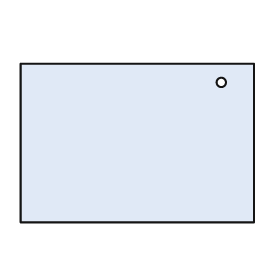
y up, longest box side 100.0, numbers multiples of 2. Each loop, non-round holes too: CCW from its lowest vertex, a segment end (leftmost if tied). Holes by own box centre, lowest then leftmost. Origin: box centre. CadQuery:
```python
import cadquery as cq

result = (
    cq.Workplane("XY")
    .moveTo(-50.0, -34.0)
    .lineTo(50.0, -34.0)
    .lineTo(50.0, 34.0)
    .lineTo(-50.0, 34.0)
    .close()
    .moveTo(36.0, 26.0)
    .circle(2.0)
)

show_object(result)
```